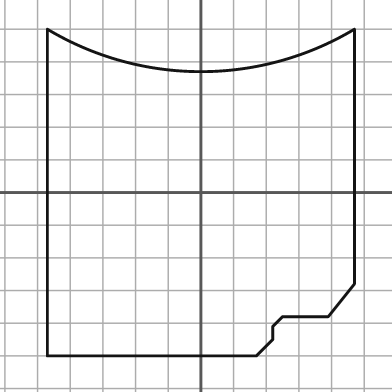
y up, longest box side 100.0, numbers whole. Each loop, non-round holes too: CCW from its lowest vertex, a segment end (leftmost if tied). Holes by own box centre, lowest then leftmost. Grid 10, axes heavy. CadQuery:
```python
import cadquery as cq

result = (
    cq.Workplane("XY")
    .moveTo(-47.0, -50.0)
    .lineTo(17.0, -50.0)
    .lineTo(22.0, -45.0)
    .lineTo(22.0, -41.0)
    .lineTo(25.0, -38.0)
    .lineTo(39.0, -38.0)
    .lineTo(47.0, -28.0)
    .lineTo(47.0, 50.0)
    .threePointArc((0.0, 37.0), (-47.0, 50.0))
    .close()
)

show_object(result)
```